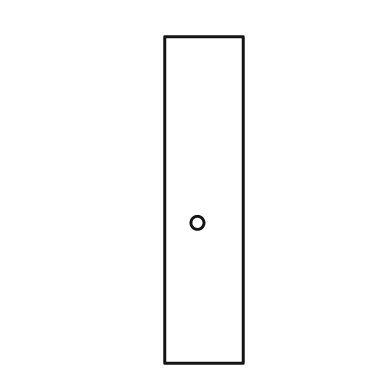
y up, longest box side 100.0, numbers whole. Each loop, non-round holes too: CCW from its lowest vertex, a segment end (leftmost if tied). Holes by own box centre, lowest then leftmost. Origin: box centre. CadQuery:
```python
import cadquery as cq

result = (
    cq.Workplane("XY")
    .moveTo(-12.0, -50.0)
    .lineTo(12.0, -50.0)
    .lineTo(12.0, 50.0)
    .lineTo(-12.0, 50.0)
    .close()
    .moveTo(-2.0, -7.0)
    .circle(2.0)
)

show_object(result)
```